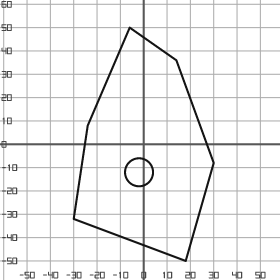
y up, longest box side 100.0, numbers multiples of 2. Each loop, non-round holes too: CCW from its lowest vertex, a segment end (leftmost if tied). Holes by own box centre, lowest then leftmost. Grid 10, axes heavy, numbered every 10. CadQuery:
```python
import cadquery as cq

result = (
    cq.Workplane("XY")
    .moveTo(18.0, -50.0)
    .lineTo(30.0, -8.0)
    .lineTo(14.0, 36.0)
    .lineTo(-6.0, 50.0)
    .lineTo(-24.0, 8.0)
    .lineTo(-30.0, -32.0)
    .close()
    .moveTo(-2.0, -12.0)
    .circle(6.0)
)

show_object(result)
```